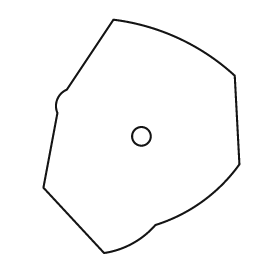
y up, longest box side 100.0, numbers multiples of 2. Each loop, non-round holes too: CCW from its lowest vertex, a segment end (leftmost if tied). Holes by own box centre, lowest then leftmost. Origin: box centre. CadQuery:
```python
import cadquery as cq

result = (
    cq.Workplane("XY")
    .moveTo(-16.0, -50.0)
    .threePointArc((-4.0, -46.0), (6.0, -38.0))
    .threePointArc((26.0, -28.0), (42.0, -12.0))
    .lineTo(40.0, 26.0)
    .threePointArc((16.0, 42.0), (-12.0, 50.0))
    .lineTo(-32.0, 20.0)
    .threePointArc((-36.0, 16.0), (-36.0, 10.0))
    .lineTo(-42.0, -22.0)
    .close()
    .moveTo(0.0, 0.0)
    .circle(4.0)
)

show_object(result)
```